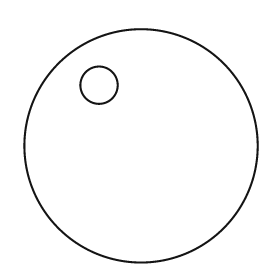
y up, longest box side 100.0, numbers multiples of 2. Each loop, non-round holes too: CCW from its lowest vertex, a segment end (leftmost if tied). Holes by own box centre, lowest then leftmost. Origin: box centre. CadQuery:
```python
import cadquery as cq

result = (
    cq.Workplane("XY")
    .moveTo(0.0, 0.0)
    .circle(50.0)
    .moveTo(-18.0, 26.0)
    .circle(8.0)
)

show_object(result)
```